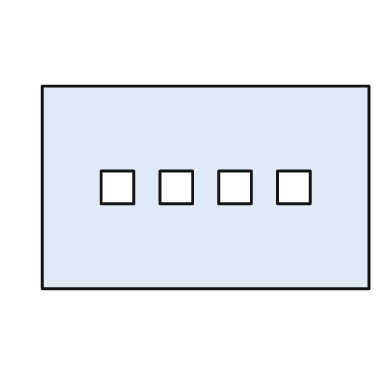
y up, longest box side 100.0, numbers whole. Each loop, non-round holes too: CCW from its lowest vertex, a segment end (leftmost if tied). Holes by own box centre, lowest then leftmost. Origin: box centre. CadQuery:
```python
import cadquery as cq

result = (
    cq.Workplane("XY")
    .moveTo(-50.0, -31.0)
    .lineTo(50.0, -31.0)
    .lineTo(50.0, 31.0)
    .lineTo(-50.0, 31.0)
    .close()
    .moveTo(-32.0, -5.0)
    .lineTo(-22.0, -5.0)
    .lineTo(-22.0, 5.0)
    .lineTo(-32.0, 5.0)
    .close()
    .moveTo(-14.0, -5.0)
    .lineTo(-4.0, -5.0)
    .lineTo(-4.0, 5.0)
    .lineTo(-14.0, 5.0)
    .close()
    .moveTo(4.0, -5.0)
    .lineTo(14.0, -5.0)
    .lineTo(14.0, 5.0)
    .lineTo(4.0, 5.0)
    .close()
    .moveTo(22.0, -5.0)
    .lineTo(32.0, -5.0)
    .lineTo(32.0, 5.0)
    .lineTo(22.0, 5.0)
    .close()
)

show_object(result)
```